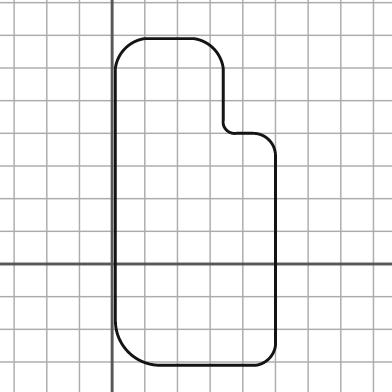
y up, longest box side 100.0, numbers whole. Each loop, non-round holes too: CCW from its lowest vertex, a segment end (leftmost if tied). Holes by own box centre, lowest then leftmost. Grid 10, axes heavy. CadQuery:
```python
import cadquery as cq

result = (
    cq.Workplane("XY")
    .moveTo(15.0, -31.0)
    .lineTo(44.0, -31.0)
    .threePointArc((48.0, -29.0), (50.0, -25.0))
    .lineTo(50.0, 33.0)
    .threePointArc((48.0, 38.0), (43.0, 40.0))
    .lineTo(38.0, 40.0)
    .threePointArc((35.0, 41.0), (34.0, 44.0))
    .lineTo(34.0, 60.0)
    .threePointArc((31.0, 66.0), (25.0, 69.0))
    .lineTo(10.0, 69.0)
    .threePointArc((4.0, 66.0), (1.0, 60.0))
    .lineTo(1.0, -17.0)
    .threePointArc((5.0, -27.0), (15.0, -31.0))
    .close()
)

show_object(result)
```